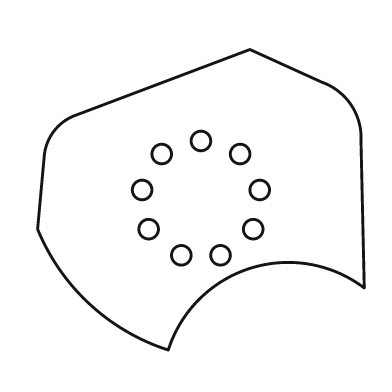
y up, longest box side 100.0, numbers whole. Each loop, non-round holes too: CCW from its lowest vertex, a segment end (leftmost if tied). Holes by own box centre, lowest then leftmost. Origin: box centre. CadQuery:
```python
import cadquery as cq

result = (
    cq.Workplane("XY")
    .moveTo(-10.0, -46.0)
    .threePointArc((15.0, -21.0), (50.0, -27.0))
    .lineTo(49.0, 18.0)
    .threePointArc((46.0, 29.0), (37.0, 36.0))
    .lineTo(15.0, 46.0)
    .lineTo(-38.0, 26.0)
    .threePointArc((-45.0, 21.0), (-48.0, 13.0))
    .lineTo(-50.0, -9.0)
    .threePointArc((-34.0, -32.0), (-10.0, -46.0))
    .close()
    .moveTo(-6.0, -17.0)
    .circle(3.0)
    .moveTo(6.0, -17.0)
    .circle(3.0)
    .moveTo(-16.0, -9.0)
    .circle(3.0)
    .moveTo(16.0, -9.0)
    .circle(3.0)
    .moveTo(-18.0, 3.0)
    .circle(3.0)
    .moveTo(18.0, 3.0)
    .circle(3.0)
    .moveTo(-12.0, 14.0)
    .circle(3.0)
    .moveTo(12.0, 14.0)
    .circle(3.0)
    .moveTo(0.0, 18.0)
    .circle(3.0)
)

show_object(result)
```